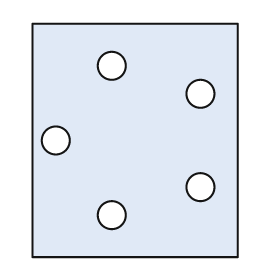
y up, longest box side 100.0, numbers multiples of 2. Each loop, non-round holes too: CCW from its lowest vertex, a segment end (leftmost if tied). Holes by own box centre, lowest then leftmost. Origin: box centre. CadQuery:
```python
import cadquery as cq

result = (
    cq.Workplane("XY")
    .moveTo(-44.0, -50.0)
    .lineTo(44.0, -50.0)
    .lineTo(44.0, 50.0)
    .lineTo(-44.0, 50.0)
    .close()
    .moveTo(-10.0, -32.0)
    .circle(6.0)
    .moveTo(28.0, -20.0)
    .circle(6.0)
    .moveTo(-34.0, 0.0)
    .circle(6.0)
    .moveTo(28.0, 20.0)
    .circle(6.0)
    .moveTo(-10.0, 32.0)
    .circle(6.0)
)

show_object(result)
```